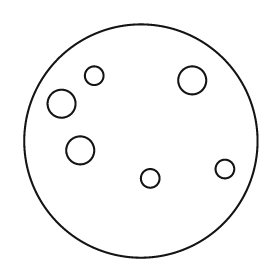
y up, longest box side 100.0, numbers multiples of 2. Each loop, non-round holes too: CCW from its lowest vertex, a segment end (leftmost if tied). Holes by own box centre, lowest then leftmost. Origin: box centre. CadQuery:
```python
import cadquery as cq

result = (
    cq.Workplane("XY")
    .moveTo(0.0, 0.0)
    .circle(50.0)
    .moveTo(4.0, -16.0)
    .circle(4.0)
    .moveTo(36.0, -12.0)
    .circle(4.0)
    .moveTo(-26.0, -4.0)
    .circle(6.0)
    .moveTo(-34.0, 16.0)
    .circle(6.0)
    .moveTo(22.0, 26.0)
    .circle(6.0)
    .moveTo(-20.0, 28.0)
    .circle(4.0)
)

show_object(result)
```